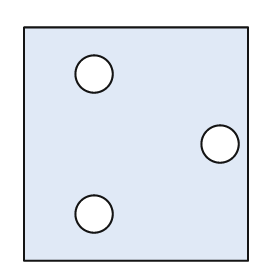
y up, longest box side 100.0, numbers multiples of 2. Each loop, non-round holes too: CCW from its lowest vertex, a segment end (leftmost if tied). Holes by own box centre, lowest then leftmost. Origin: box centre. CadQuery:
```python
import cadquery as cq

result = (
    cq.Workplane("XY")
    .moveTo(-48.0, -50.0)
    .lineTo(48.0, -50.0)
    .lineTo(48.0, 50.0)
    .lineTo(-48.0, 50.0)
    .close()
    .moveTo(-18.0, -30.0)
    .circle(8.0)
    .moveTo(36.0, 0.0)
    .circle(8.0)
    .moveTo(-18.0, 30.0)
    .circle(8.0)
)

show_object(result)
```